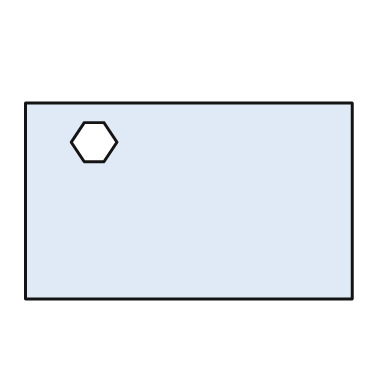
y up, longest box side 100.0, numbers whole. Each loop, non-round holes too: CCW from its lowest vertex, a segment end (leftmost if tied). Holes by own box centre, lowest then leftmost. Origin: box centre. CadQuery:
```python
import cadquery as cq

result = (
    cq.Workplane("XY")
    .moveTo(-50.0, -30.0)
    .lineTo(50.0, -30.0)
    .lineTo(50.0, 30.0)
    .lineTo(-50.0, 30.0)
    .close()
    .moveTo(-32.0, 12.0)
    .lineTo(-26.0, 12.0)
    .lineTo(-22.0, 18.0)
    .lineTo(-26.0, 24.0)
    .lineTo(-32.0, 24.0)
    .lineTo(-36.0, 18.0)
    .close()
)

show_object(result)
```